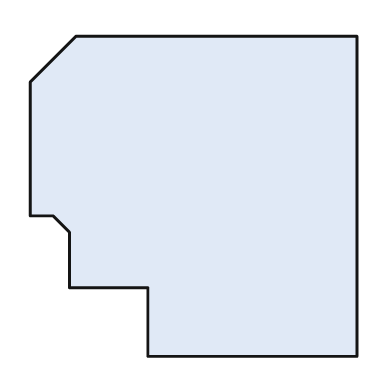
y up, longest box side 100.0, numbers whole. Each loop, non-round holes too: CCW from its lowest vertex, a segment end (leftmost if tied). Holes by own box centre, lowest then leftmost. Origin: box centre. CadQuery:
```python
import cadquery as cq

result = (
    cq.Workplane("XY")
    .moveTo(-14.0, -49.0)
    .lineTo(50.0, -49.0)
    .lineTo(50.0, 49.0)
    .lineTo(-36.0, 49.0)
    .lineTo(-50.0, 35.0)
    .lineTo(-50.0, -6.0)
    .lineTo(-43.0, -6.0)
    .lineTo(-38.0, -11.0)
    .lineTo(-38.0, -28.0)
    .lineTo(-14.0, -28.0)
    .close()
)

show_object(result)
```